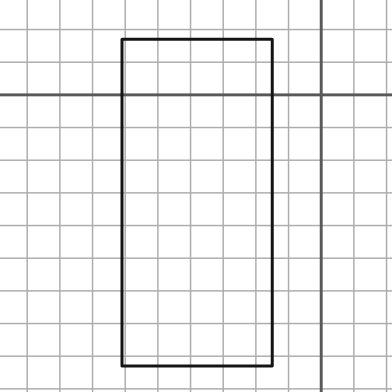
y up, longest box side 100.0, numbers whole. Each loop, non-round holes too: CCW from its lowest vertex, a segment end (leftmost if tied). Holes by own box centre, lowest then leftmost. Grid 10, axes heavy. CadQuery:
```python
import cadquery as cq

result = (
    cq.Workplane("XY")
    .moveTo(-61.0, -83.0)
    .lineTo(-15.0, -83.0)
    .lineTo(-15.0, 17.0)
    .lineTo(-61.0, 17.0)
    .close()
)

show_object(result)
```